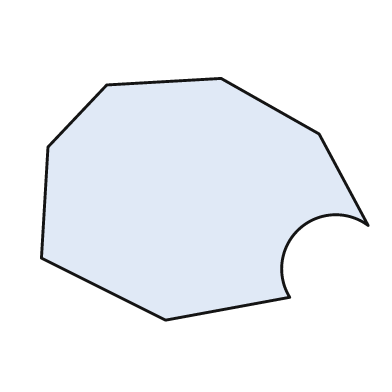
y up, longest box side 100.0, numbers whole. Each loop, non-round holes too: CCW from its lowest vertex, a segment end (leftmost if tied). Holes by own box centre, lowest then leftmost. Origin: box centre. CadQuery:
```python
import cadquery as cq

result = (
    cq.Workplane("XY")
    .moveTo(-12.0, -37.0)
    .lineTo(26.0, -30.0)
    .threePointArc((29.0, -9.0), (50.0, -8.0))
    .lineTo(35.0, 20.0)
    .lineTo(5.0, 37.0)
    .lineTo(-30.0, 35.0)
    .lineTo(-48.0, 16.0)
    .lineTo(-50.0, -18.0)
    .close()
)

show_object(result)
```